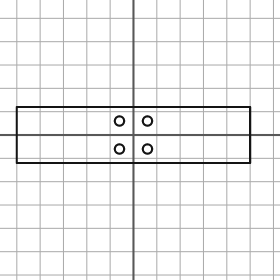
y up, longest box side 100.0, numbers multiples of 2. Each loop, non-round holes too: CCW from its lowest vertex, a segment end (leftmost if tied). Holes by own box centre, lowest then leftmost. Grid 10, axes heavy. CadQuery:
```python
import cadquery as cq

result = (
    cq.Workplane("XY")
    .moveTo(-50.0, -12.0)
    .lineTo(50.0, -12.0)
    .lineTo(50.0, 12.0)
    .lineTo(-50.0, 12.0)
    .close()
    .moveTo(-6.0, -6.0)
    .circle(2.0)
    .moveTo(6.0, -6.0)
    .circle(2.0)
    .moveTo(-6.0, 6.0)
    .circle(2.0)
    .moveTo(6.0, 6.0)
    .circle(2.0)
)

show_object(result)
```